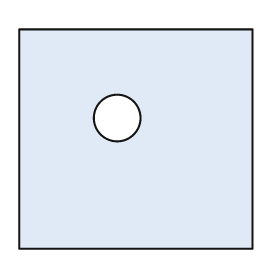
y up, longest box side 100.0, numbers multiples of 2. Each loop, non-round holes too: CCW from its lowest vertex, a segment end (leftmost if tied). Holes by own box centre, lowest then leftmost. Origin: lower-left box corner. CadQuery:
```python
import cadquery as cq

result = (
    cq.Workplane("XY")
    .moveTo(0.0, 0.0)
    .lineTo(100.0, 0.0)
    .lineTo(100.0, 94.0)
    .lineTo(0.0, 94.0)
    .close()
    .moveTo(42.0, 56.0)
    .circle(10.0)
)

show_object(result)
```